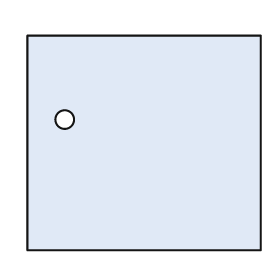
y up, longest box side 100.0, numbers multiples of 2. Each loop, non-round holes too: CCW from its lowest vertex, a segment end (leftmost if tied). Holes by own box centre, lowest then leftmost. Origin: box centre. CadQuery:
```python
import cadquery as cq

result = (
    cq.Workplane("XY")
    .moveTo(-50.0, -46.0)
    .lineTo(50.0, -46.0)
    .lineTo(50.0, 46.0)
    .lineTo(-50.0, 46.0)
    .close()
    .moveTo(-34.0, 10.0)
    .circle(4.0)
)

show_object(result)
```